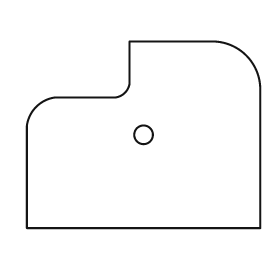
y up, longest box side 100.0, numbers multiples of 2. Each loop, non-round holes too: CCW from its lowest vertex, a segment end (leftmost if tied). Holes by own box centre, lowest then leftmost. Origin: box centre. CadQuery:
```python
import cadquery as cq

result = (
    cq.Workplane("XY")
    .moveTo(-50.0, -40.0)
    .lineTo(50.0, -40.0)
    .lineTo(50.0, 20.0)
    .threePointArc((44.0, 34.0), (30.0, 40.0))
    .lineTo(-6.0, 40.0)
    .lineTo(-6.0, 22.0)
    .threePointArc((-8.0, 18.0), (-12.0, 16.0))
    .lineTo(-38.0, 16.0)
    .threePointArc((-46.0, 12.0), (-50.0, 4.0))
    .close()
    .moveTo(0.0, 0.0)
    .circle(4.0)
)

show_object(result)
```